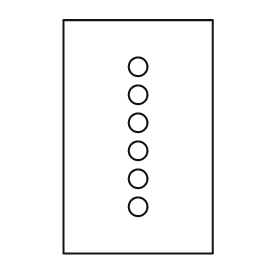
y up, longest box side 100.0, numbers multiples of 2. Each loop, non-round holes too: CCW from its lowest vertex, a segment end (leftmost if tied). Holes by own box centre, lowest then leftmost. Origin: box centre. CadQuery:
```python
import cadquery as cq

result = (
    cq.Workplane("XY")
    .moveTo(-32.0, -50.0)
    .lineTo(32.0, -50.0)
    .lineTo(32.0, 50.0)
    .lineTo(-32.0, 50.0)
    .close()
    .moveTo(0.0, -30.0)
    .circle(4.0)
    .moveTo(0.0, -18.0)
    .circle(4.0)
    .moveTo(0.0, -6.0)
    .circle(4.0)
    .moveTo(0.0, 6.0)
    .circle(4.0)
    .moveTo(0.0, 18.0)
    .circle(4.0)
    .moveTo(0.0, 30.0)
    .circle(4.0)
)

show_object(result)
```